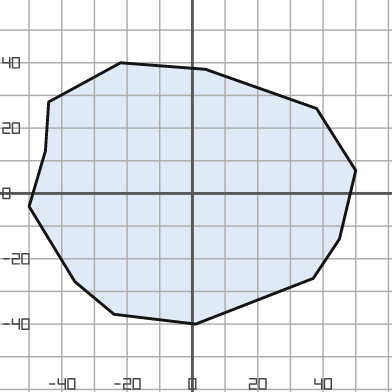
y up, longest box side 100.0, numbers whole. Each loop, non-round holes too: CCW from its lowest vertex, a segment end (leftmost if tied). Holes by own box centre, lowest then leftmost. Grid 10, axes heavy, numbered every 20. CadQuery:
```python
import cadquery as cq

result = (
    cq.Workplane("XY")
    .moveTo(1.0, -40.0)
    .lineTo(37.0, -26.0)
    .lineTo(45.0, -14.0)
    .lineTo(50.0, 7.0)
    .lineTo(38.0, 26.0)
    .lineTo(4.0, 38.0)
    .lineTo(-22.0, 40.0)
    .lineTo(-44.0, 28.0)
    .lineTo(-45.0, 13.0)
    .lineTo(-50.0, -4.0)
    .lineTo(-36.0, -27.0)
    .lineTo(-24.0, -37.0)
    .close()
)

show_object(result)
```